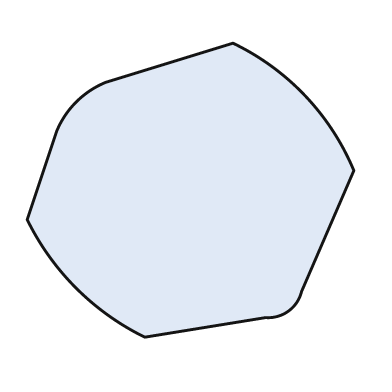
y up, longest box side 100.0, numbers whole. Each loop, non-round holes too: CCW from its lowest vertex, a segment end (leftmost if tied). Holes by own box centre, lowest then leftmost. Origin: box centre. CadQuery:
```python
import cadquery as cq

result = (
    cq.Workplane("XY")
    .moveTo(-14.0, -45.0)
    .lineTo(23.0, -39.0)
    .threePointArc((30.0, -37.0), (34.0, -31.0))
    .lineTo(50.0, 6.0)
    .threePointArc((35.0, 29.0), (13.0, 45.0))
    .lineTo(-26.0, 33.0)
    .threePointArc((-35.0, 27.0), (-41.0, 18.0))
    .lineTo(-50.0, -9.0)
    .threePointArc((-35.0, -30.0), (-14.0, -45.0))
    .close()
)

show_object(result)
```